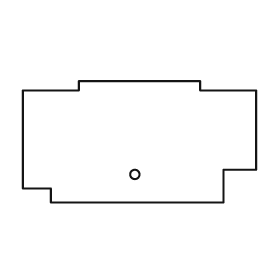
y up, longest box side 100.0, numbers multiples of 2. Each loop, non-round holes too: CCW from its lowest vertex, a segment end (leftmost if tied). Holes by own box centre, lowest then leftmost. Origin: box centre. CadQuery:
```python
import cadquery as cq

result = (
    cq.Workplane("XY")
    .moveTo(-38.0, -26.0)
    .lineTo(36.0, -26.0)
    .lineTo(36.0, -12.0)
    .lineTo(50.0, -12.0)
    .lineTo(50.0, 22.0)
    .lineTo(26.0, 22.0)
    .lineTo(26.0, 26.0)
    .lineTo(-26.0, 26.0)
    .lineTo(-26.0, 22.0)
    .lineTo(-50.0, 22.0)
    .lineTo(-50.0, -20.0)
    .lineTo(-38.0, -20.0)
    .close()
    .moveTo(-2.0, -14.0)
    .circle(2.0)
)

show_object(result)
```